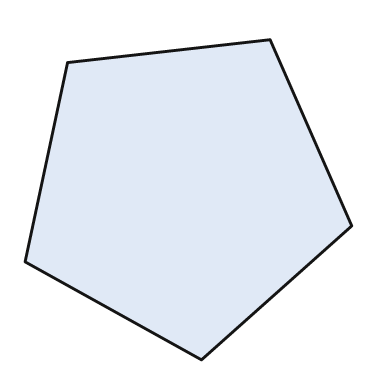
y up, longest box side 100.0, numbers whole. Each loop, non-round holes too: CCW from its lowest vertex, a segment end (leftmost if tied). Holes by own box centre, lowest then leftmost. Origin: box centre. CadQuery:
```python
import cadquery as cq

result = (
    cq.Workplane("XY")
    .moveTo(4.0, -49.0)
    .lineTo(50.0, -8.0)
    .lineTo(25.0, 49.0)
    .lineTo(-37.0, 42.0)
    .lineTo(-50.0, -19.0)
    .close()
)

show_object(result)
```